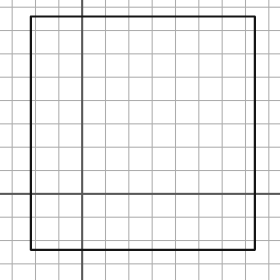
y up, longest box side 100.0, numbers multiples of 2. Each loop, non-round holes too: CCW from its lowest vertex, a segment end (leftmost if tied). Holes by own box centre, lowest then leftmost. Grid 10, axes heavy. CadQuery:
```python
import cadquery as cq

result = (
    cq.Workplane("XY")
    .moveTo(-22.0, -24.0)
    .lineTo(74.0, -24.0)
    .lineTo(74.0, 76.0)
    .lineTo(-22.0, 76.0)
    .close()
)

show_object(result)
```